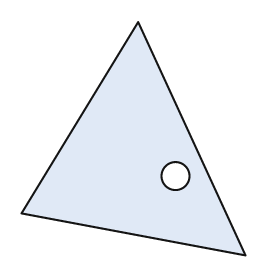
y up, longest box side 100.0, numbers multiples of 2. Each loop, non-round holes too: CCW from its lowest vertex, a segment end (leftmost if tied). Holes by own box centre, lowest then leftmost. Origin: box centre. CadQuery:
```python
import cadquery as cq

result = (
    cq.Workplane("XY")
    .moveTo(48.0, -50.0)
    .lineTo(2.0, 50.0)
    .lineTo(-48.0, -32.0)
    .close()
    .moveTo(18.0, -16.0)
    .circle(6.0)
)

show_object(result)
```